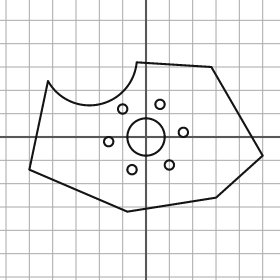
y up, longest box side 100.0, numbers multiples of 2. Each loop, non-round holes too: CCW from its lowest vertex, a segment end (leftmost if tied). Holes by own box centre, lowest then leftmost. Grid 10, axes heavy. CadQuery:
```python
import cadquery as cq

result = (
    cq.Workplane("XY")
    .moveTo(-8.0, -32.0)
    .lineTo(30.0, -26.0)
    .lineTo(50.0, -8.0)
    .lineTo(28.0, 30.0)
    .lineTo(-4.0, 32.0)
    .threePointArc((-20.0, 14.0), (-42.0, 24.0))
    .lineTo(-50.0, -14.0)
    .close()
    .moveTo(-6.0, -14.0)
    .circle(2.0)
    .moveTo(10.0, -12.0)
    .circle(2.0)
    .moveTo(-16.0, -2.0)
    .circle(2.0)
    .moveTo(0.0, 0.0)
    .circle(8.0)
    .moveTo(16.0, 2.0)
    .circle(2.0)
    .moveTo(-10.0, 12.0)
    .circle(2.0)
    .moveTo(6.0, 14.0)
    .circle(2.0)
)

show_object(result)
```